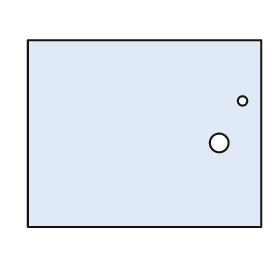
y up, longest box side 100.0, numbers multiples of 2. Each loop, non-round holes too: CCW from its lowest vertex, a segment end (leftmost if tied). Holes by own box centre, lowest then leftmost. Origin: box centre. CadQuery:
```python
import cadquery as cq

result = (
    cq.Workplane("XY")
    .moveTo(-50.0, -40.0)
    .lineTo(50.0, -40.0)
    .lineTo(50.0, 40.0)
    .lineTo(-50.0, 40.0)
    .close()
    .moveTo(32.0, -4.0)
    .circle(4.0)
    .moveTo(42.0, 14.0)
    .circle(2.0)
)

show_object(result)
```